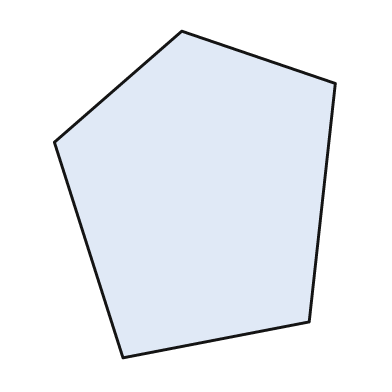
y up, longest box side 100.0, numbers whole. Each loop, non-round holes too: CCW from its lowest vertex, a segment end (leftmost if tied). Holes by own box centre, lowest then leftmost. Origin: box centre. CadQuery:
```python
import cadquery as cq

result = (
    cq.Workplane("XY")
    .moveTo(-22.0, -50.0)
    .lineTo(35.0, -39.0)
    .lineTo(43.0, 34.0)
    .lineTo(-4.0, 50.0)
    .lineTo(-43.0, 16.0)
    .close()
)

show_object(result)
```